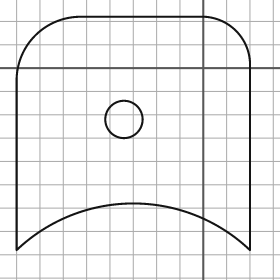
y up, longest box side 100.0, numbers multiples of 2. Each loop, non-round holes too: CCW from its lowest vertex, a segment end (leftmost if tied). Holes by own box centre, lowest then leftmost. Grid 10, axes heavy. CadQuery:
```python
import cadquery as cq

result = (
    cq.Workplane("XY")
    .moveTo(-80.0, -78.0)
    .threePointArc((-30.0, -58.0), (20.0, -78.0))
    .lineTo(20.0, 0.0)
    .threePointArc((14.0, 16.0), (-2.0, 22.0))
    .lineTo(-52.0, 22.0)
    .threePointArc((-72.0, 14.0), (-80.0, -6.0))
    .close()
    .moveTo(-34.0, -22.0)
    .circle(8.0)
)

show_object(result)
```